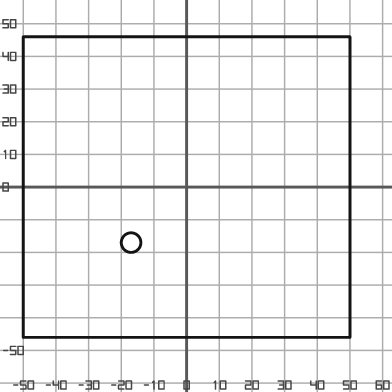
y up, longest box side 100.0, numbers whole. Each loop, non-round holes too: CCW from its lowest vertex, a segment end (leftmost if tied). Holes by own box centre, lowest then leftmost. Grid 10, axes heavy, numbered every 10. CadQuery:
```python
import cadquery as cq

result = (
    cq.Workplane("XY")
    .moveTo(-50.0, -46.0)
    .lineTo(50.0, -46.0)
    .lineTo(50.0, 46.0)
    .lineTo(-50.0, 46.0)
    .close()
    .moveTo(-17.0, -17.0)
    .circle(3.0)
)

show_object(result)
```